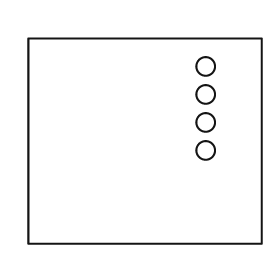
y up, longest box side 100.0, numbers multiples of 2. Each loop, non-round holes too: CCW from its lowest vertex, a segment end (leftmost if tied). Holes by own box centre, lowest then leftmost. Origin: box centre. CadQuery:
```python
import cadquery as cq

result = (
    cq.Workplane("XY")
    .moveTo(-50.0, -44.0)
    .lineTo(50.0, -44.0)
    .lineTo(50.0, 44.0)
    .lineTo(-50.0, 44.0)
    .close()
    .moveTo(26.0, -4.0)
    .circle(4.0)
    .moveTo(26.0, 8.0)
    .circle(4.0)
    .moveTo(26.0, 20.0)
    .circle(4.0)
    .moveTo(26.0, 32.0)
    .circle(4.0)
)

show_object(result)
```